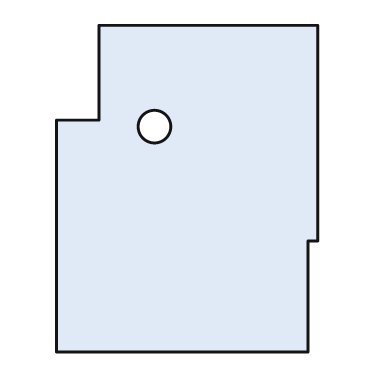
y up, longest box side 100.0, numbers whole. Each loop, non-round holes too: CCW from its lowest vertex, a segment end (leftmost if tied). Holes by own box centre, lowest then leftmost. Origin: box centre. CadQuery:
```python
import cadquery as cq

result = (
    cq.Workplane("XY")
    .moveTo(-40.0, -50.0)
    .lineTo(37.0, -50.0)
    .lineTo(37.0, -16.0)
    .lineTo(40.0, -16.0)
    .lineTo(40.0, 50.0)
    .lineTo(-27.0, 50.0)
    .lineTo(-27.0, 21.0)
    .lineTo(-40.0, 21.0)
    .close()
    .moveTo(-10.0, 19.0)
    .circle(5.0)
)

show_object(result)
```